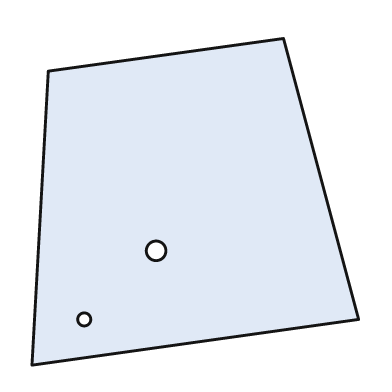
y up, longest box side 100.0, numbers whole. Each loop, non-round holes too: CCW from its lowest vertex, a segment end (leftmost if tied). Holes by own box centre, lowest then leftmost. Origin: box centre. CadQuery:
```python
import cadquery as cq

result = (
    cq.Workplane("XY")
    .moveTo(-50.0, -50.0)
    .lineTo(50.0, -36.0)
    .lineTo(27.0, 50.0)
    .lineTo(-45.0, 40.0)
    .close()
    .moveTo(-34.0, -36.0)
    .circle(2.0)
    .moveTo(-12.0, -15.0)
    .circle(3.0)
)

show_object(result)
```